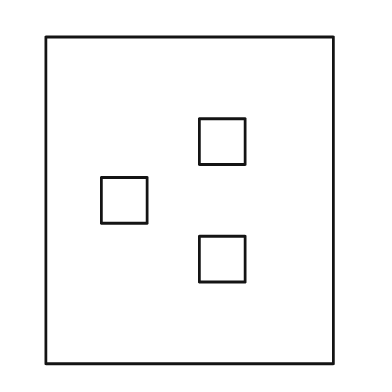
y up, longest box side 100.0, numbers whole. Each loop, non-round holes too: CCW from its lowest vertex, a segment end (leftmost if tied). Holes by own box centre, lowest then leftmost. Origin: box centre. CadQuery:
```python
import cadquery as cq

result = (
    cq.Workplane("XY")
    .moveTo(-44.0, -50.0)
    .lineTo(44.0, -50.0)
    .lineTo(44.0, 50.0)
    .lineTo(-44.0, 50.0)
    .close()
    .moveTo(3.0, -25.0)
    .lineTo(17.0, -25.0)
    .lineTo(17.0, -11.0)
    .lineTo(3.0, -11.0)
    .close()
    .moveTo(-27.0, -7.0)
    .lineTo(-13.0, -7.0)
    .lineTo(-13.0, 7.0)
    .lineTo(-27.0, 7.0)
    .close()
    .moveTo(3.0, 11.0)
    .lineTo(17.0, 11.0)
    .lineTo(17.0, 25.0)
    .lineTo(3.0, 25.0)
    .close()
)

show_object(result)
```